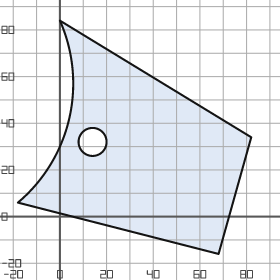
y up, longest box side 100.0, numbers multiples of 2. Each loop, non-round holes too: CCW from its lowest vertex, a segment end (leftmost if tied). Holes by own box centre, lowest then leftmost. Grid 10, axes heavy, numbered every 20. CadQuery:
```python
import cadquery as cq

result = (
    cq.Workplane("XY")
    .moveTo(68.0, -16.0)
    .lineTo(82.0, 34.0)
    .lineTo(0.0, 84.0)
    .threePointArc((4.0, 42.0), (-18.0, 6.0))
    .close()
    .moveTo(14.0, 32.0)
    .circle(6.0)
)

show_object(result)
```